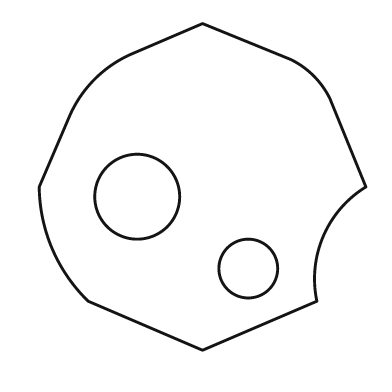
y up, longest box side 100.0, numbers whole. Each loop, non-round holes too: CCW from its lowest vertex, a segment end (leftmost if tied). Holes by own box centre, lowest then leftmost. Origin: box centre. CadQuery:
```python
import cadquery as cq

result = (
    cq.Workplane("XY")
    .moveTo(0.0, -50.0)
    .lineTo(35.0, -35.0)
    .threePointArc((37.0, -15.0), (50.0, 0.0))
    .lineTo(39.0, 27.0)
    .threePointArc((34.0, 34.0), (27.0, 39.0))
    .lineTo(0.0, 50.0)
    .lineTo(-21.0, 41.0)
    .threePointArc((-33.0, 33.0), (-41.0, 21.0))
    .lineTo(-50.0, 0.0)
    .threePointArc((-46.0, -19.0), (-35.0, -35.0))
    .close()
    .moveTo(14.0, -25.0)
    .circle(9.0)
    .moveTo(-20.0, -3.0)
    .circle(13.0)
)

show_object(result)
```